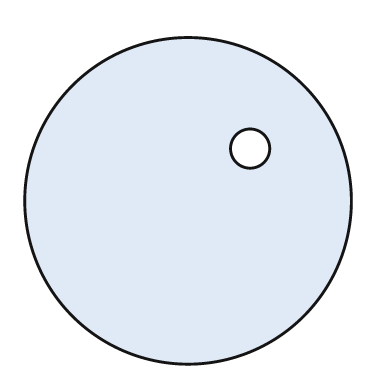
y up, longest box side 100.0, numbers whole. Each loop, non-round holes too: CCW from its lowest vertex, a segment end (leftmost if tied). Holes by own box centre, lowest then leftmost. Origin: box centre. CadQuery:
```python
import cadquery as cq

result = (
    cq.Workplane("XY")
    .moveTo(0.0, 0.0)
    .circle(50.0)
    .moveTo(19.0, 16.0)
    .circle(6.0)
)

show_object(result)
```